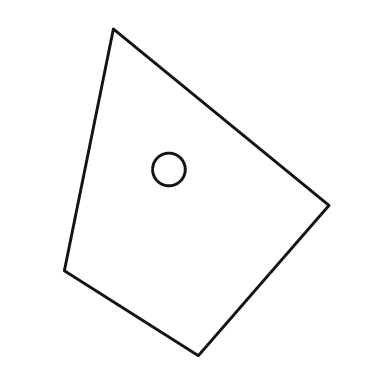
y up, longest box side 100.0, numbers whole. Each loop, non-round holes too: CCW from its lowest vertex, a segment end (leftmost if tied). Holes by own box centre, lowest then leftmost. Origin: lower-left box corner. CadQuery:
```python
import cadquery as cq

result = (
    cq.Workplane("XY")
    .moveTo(41.0, 0.0)
    .lineTo(81.0, 46.0)
    .lineTo(15.0, 100.0)
    .lineTo(0.0, 26.0)
    .close()
    .moveTo(32.0, 57.0)
    .circle(5.0)
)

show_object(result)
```